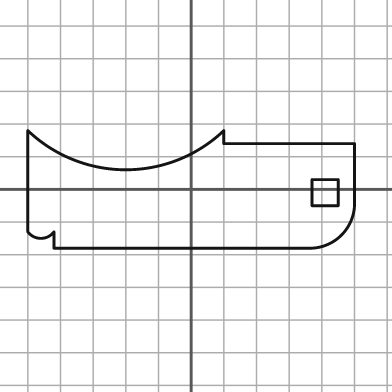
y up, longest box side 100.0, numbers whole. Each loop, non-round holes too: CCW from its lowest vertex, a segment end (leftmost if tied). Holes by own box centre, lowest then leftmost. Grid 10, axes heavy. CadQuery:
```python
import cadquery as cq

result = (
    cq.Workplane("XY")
    .moveTo(-42.0, -18.0)
    .lineTo(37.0, -18.0)
    .threePointArc((46.0, -14.0), (50.0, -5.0))
    .lineTo(50.0, 14.0)
    .lineTo(10.0, 14.0)
    .lineTo(10.0, 18.0)
    .threePointArc((-20.0, 6.0), (-50.0, 18.0))
    .lineTo(-50.0, -13.0)
    .threePointArc((-46.0, -15.0), (-42.0, -13.0))
    .close()
    .moveTo(37.0, -5.0)
    .lineTo(45.0, -5.0)
    .lineTo(45.0, 3.0)
    .lineTo(37.0, 3.0)
    .close()
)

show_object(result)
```